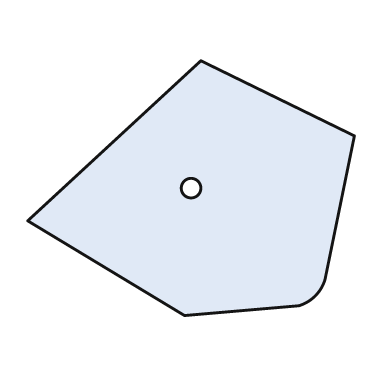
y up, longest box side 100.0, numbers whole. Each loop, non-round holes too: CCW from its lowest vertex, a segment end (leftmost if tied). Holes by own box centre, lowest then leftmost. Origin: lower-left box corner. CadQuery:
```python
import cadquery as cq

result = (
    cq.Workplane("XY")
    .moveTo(48.0, 0.0)
    .lineTo(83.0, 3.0)
    .threePointArc((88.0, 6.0), (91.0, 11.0))
    .lineTo(100.0, 55.0)
    .lineTo(53.0, 78.0)
    .lineTo(0.0, 29.0)
    .close()
    .moveTo(50.0, 39.0)
    .circle(3.0)
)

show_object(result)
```